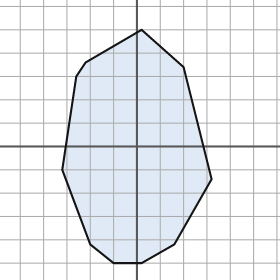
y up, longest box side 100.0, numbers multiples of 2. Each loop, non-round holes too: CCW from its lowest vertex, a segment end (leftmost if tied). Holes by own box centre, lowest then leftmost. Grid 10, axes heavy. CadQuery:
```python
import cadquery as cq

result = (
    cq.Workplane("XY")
    .moveTo(-10.0, -50.0)
    .lineTo(2.0, -50.0)
    .lineTo(16.0, -42.0)
    .lineTo(32.0, -14.0)
    .lineTo(20.0, 34.0)
    .lineTo(2.0, 50.0)
    .lineTo(-22.0, 36.0)
    .lineTo(-26.0, 30.0)
    .lineTo(-32.0, -10.0)
    .lineTo(-20.0, -42.0)
    .close()
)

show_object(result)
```